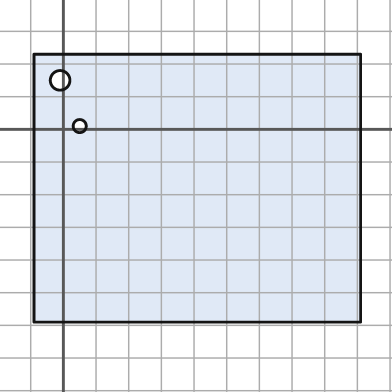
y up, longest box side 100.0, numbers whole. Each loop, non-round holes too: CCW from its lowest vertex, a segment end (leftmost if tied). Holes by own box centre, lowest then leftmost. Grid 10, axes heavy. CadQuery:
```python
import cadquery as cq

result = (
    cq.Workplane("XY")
    .moveTo(-9.0, -59.0)
    .lineTo(91.0, -59.0)
    .lineTo(91.0, 23.0)
    .lineTo(-9.0, 23.0)
    .close()
    .moveTo(5.0, 1.0)
    .circle(2.0)
    .moveTo(-1.0, 15.0)
    .circle(3.0)
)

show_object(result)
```